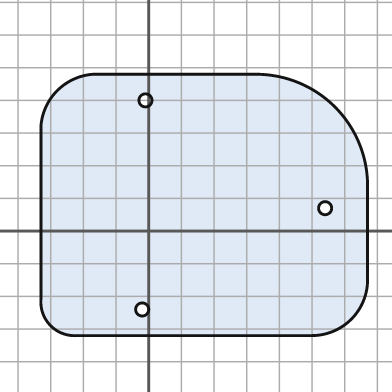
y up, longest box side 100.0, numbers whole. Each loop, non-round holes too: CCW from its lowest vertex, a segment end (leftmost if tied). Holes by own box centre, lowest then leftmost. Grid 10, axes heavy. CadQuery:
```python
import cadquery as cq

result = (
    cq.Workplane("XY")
    .moveTo(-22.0, -32.0)
    .lineTo(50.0, -32.0)
    .threePointArc((62.0, -27.0), (67.0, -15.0))
    .lineTo(67.0, 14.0)
    .threePointArc((57.0, 38.0), (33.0, 48.0))
    .lineTo(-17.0, 48.0)
    .threePointArc((-28.0, 43.0), (-33.0, 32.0))
    .lineTo(-33.0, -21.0)
    .threePointArc((-30.0, -29.0), (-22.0, -32.0))
    .close()
    .moveTo(-2.0, -24.0)
    .circle(2.0)
    .moveTo(54.0, 7.0)
    .circle(2.0)
    .moveTo(-1.0, 40.0)
    .circle(2.0)
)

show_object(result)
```